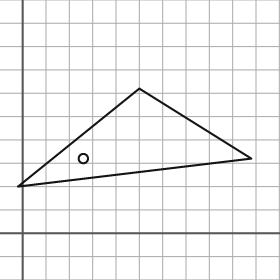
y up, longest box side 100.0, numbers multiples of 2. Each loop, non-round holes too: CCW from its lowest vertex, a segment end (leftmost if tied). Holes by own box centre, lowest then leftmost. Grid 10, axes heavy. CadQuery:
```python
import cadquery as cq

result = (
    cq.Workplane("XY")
    .moveTo(-2.0, 20.0)
    .lineTo(98.0, 32.0)
    .lineTo(50.0, 62.0)
    .close()
    .moveTo(26.0, 32.0)
    .circle(2.0)
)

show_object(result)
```